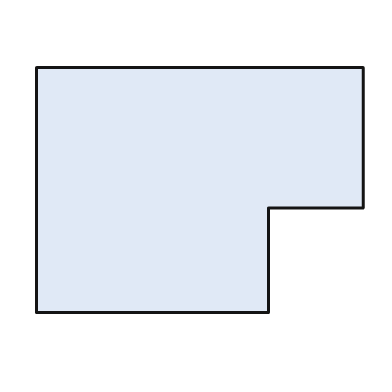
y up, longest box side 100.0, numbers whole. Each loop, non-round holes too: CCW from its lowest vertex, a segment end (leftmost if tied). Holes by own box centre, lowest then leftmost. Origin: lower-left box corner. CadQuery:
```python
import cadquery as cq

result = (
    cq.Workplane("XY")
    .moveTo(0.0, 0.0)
    .lineTo(71.0, 0.0)
    .lineTo(71.0, 32.0)
    .lineTo(100.0, 32.0)
    .lineTo(100.0, 75.0)
    .lineTo(0.0, 75.0)
    .close()
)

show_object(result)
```